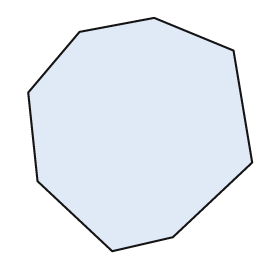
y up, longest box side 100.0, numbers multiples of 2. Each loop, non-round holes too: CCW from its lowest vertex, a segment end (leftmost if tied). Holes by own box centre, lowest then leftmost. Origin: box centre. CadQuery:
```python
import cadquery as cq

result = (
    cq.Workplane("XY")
    .moveTo(-12.0, -50.0)
    .lineTo(14.0, -44.0)
    .lineTo(48.0, -12.0)
    .lineTo(40.0, 36.0)
    .lineTo(6.0, 50.0)
    .lineTo(-26.0, 44.0)
    .lineTo(-48.0, 18.0)
    .lineTo(-44.0, -20.0)
    .close()
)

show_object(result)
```